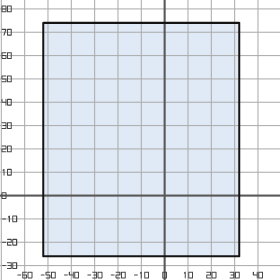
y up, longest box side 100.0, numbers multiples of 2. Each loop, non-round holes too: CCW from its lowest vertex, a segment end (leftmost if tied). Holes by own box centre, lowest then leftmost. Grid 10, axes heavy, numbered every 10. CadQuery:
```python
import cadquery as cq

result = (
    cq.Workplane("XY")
    .moveTo(-52.0, -26.0)
    .lineTo(32.0, -26.0)
    .lineTo(32.0, 74.0)
    .lineTo(-52.0, 74.0)
    .close()
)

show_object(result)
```